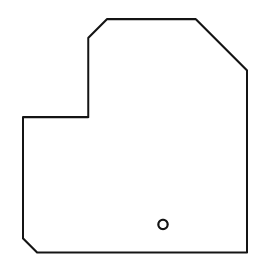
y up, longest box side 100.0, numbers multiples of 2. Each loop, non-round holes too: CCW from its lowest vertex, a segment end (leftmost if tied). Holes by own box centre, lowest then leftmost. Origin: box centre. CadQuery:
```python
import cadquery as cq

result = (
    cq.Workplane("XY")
    .moveTo(-42.0, -50.0)
    .lineTo(48.0, -50.0)
    .lineTo(48.0, 28.0)
    .lineTo(26.0, 50.0)
    .lineTo(-12.0, 50.0)
    .lineTo(-20.0, 42.0)
    .lineTo(-20.0, 8.0)
    .lineTo(-48.0, 8.0)
    .lineTo(-48.0, -44.0)
    .close()
    .moveTo(12.0, -38.0)
    .circle(2.0)
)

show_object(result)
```